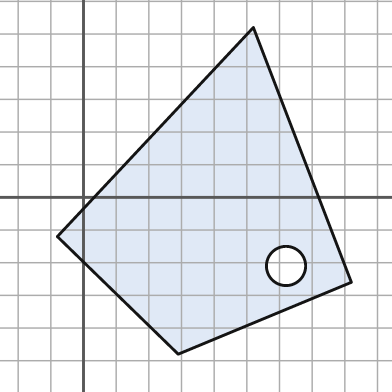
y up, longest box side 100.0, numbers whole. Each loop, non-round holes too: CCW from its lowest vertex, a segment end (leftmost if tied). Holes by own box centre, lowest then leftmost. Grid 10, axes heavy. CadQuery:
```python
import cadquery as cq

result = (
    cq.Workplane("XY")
    .moveTo(29.0, -48.0)
    .lineTo(82.0, -26.0)
    .lineTo(52.0, 52.0)
    .lineTo(-8.0, -12.0)
    .close()
    .moveTo(62.0, -21.0)
    .circle(6.0)
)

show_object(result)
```